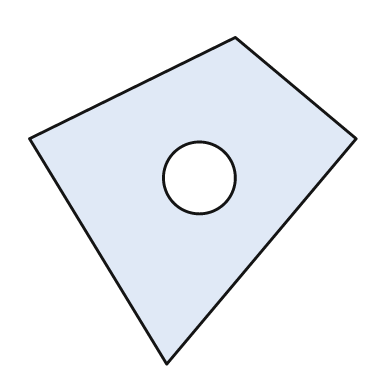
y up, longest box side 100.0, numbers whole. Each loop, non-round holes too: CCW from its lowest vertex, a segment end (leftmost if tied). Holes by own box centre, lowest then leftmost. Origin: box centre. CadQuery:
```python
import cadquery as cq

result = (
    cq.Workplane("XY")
    .moveTo(-8.0, -50.0)
    .lineTo(50.0, 19.0)
    .lineTo(13.0, 50.0)
    .lineTo(-50.0, 19.0)
    .close()
    .moveTo(2.0, 7.0)
    .circle(11.0)
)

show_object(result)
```